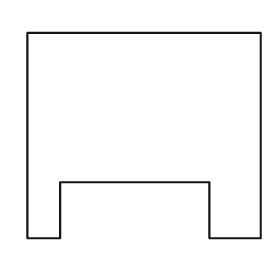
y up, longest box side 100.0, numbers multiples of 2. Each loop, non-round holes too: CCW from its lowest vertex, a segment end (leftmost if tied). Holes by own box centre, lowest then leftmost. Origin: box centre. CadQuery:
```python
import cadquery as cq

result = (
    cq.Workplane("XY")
    .moveTo(-50.0, -44.0)
    .lineTo(-36.0, -44.0)
    .lineTo(-36.0, -20.0)
    .lineTo(28.0, -20.0)
    .lineTo(28.0, -44.0)
    .lineTo(50.0, -44.0)
    .lineTo(50.0, 44.0)
    .lineTo(-50.0, 44.0)
    .close()
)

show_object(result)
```